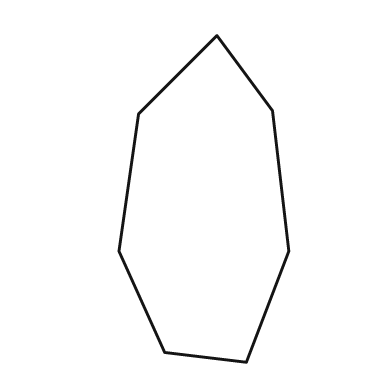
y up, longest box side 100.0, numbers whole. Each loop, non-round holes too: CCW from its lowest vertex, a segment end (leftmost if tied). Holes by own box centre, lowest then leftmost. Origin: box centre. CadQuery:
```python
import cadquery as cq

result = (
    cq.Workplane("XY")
    .moveTo(13.0, -50.0)
    .lineTo(26.0, -16.0)
    .lineTo(21.0, 27.0)
    .lineTo(4.0, 50.0)
    .lineTo(-20.0, 26.0)
    .lineTo(-26.0, -16.0)
    .lineTo(-12.0, -47.0)
    .close()
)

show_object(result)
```